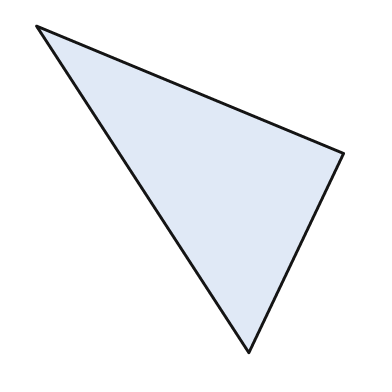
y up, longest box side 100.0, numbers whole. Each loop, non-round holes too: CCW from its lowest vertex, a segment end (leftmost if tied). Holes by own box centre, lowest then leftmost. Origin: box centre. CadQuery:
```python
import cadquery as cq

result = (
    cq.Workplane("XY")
    .moveTo(18.0, -50.0)
    .lineTo(47.0, 11.0)
    .lineTo(-47.0, 50.0)
    .close()
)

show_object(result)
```